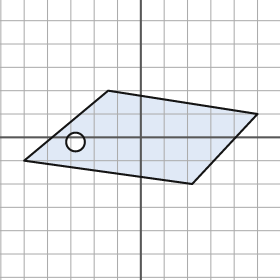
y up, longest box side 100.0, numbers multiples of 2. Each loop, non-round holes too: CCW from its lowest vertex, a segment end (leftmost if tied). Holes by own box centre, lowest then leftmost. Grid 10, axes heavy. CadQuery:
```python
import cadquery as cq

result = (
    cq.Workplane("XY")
    .moveTo(22.0, -20.0)
    .lineTo(50.0, 10.0)
    .lineTo(-14.0, 20.0)
    .lineTo(-50.0, -10.0)
    .close()
    .moveTo(-28.0, -2.0)
    .circle(4.0)
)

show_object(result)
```